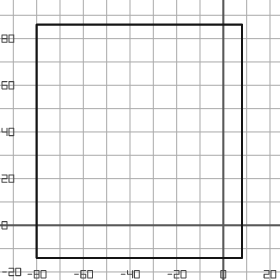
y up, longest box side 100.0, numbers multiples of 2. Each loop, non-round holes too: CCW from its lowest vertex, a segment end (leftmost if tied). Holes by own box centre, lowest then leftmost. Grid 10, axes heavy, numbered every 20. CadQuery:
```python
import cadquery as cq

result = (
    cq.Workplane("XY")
    .moveTo(-80.0, -14.0)
    .lineTo(8.0, -14.0)
    .lineTo(8.0, 86.0)
    .lineTo(-80.0, 86.0)
    .close()
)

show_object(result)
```